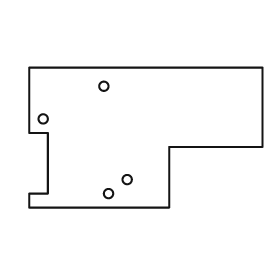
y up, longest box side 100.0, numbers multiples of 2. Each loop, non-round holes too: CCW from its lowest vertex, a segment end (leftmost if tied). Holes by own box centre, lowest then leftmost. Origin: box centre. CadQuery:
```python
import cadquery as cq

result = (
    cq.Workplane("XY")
    .moveTo(-50.0, -30.0)
    .lineTo(10.0, -30.0)
    .lineTo(10.0, -4.0)
    .lineTo(50.0, -4.0)
    .lineTo(50.0, 30.0)
    .lineTo(-50.0, 30.0)
    .lineTo(-50.0, 2.0)
    .lineTo(-42.0, 2.0)
    .lineTo(-42.0, -24.0)
    .lineTo(-50.0, -24.0)
    .close()
    .moveTo(-16.0, -24.0)
    .circle(2.0)
    .moveTo(-8.0, -18.0)
    .circle(2.0)
    .moveTo(-44.0, 8.0)
    .circle(2.0)
    .moveTo(-18.0, 22.0)
    .circle(2.0)
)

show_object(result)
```